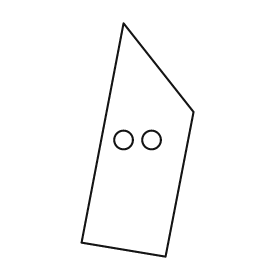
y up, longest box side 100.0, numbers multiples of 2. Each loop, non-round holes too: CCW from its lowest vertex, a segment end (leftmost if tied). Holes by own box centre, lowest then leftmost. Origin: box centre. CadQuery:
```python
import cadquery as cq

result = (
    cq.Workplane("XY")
    .moveTo(12.0, -50.0)
    .lineTo(24.0, 12.0)
    .lineTo(-6.0, 50.0)
    .lineTo(-24.0, -44.0)
    .close()
    .moveTo(-6.0, 0.0)
    .circle(4.0)
    .moveTo(6.0, 0.0)
    .circle(4.0)
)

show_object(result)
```